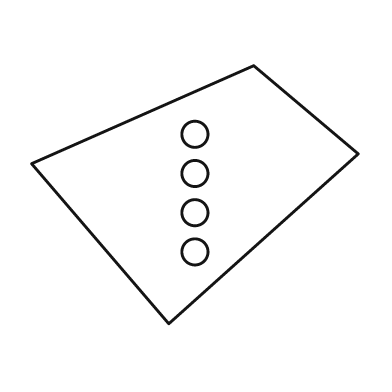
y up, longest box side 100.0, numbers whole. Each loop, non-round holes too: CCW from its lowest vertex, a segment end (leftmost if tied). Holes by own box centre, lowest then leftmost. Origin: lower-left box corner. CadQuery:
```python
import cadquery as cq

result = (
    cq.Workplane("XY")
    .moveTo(42.0, 0.0)
    .lineTo(100.0, 52.0)
    .lineTo(68.0, 79.0)
    .lineTo(0.0, 49.0)
    .close()
    .moveTo(50.0, 22.0)
    .circle(4.0)
    .moveTo(50.0, 34.0)
    .circle(4.0)
    .moveTo(50.0, 46.0)
    .circle(4.0)
    .moveTo(50.0, 58.0)
    .circle(4.0)
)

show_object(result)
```